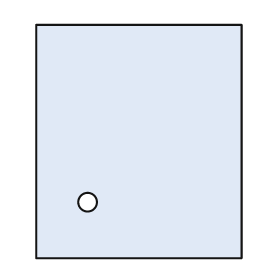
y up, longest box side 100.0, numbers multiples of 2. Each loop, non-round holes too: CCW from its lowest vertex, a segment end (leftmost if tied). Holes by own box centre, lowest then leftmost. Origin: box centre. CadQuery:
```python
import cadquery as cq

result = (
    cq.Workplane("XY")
    .moveTo(-44.0, -50.0)
    .lineTo(44.0, -50.0)
    .lineTo(44.0, 50.0)
    .lineTo(-44.0, 50.0)
    .close()
    .moveTo(-22.0, -26.0)
    .circle(4.0)
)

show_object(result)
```